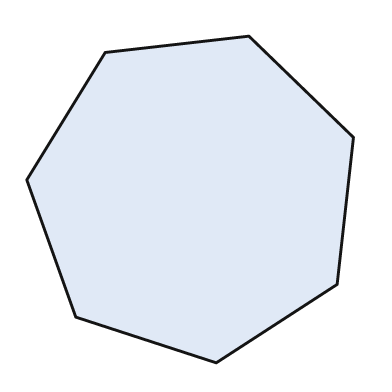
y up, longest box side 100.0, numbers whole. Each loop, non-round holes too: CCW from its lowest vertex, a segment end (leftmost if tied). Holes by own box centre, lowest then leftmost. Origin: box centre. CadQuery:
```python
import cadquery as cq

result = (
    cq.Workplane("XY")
    .moveTo(8.0, -50.0)
    .lineTo(45.0, -26.0)
    .lineTo(50.0, 19.0)
    .lineTo(18.0, 50.0)
    .lineTo(-26.0, 45.0)
    .lineTo(-50.0, 6.0)
    .lineTo(-35.0, -36.0)
    .close()
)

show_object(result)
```